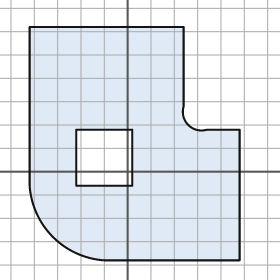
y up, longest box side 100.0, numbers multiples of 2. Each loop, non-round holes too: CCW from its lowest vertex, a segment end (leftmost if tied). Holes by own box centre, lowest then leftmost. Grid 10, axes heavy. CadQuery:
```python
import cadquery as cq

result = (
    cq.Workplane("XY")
    .moveTo(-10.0, -38.0)
    .lineTo(48.0, -38.0)
    .lineTo(48.0, 18.0)
    .lineTo(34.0, 18.0)
    .threePointArc((26.0, 20.0), (24.0, 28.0))
    .lineTo(24.0, 62.0)
    .lineTo(-42.0, 62.0)
    .lineTo(-42.0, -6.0)
    .threePointArc((-32.0, -28.0), (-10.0, -38.0))
    .close()
    .moveTo(-22.0, -6.0)
    .lineTo(2.0, -6.0)
    .lineTo(2.0, 18.0)
    .lineTo(-22.0, 18.0)
    .close()
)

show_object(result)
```